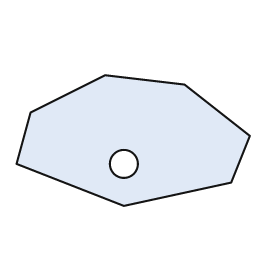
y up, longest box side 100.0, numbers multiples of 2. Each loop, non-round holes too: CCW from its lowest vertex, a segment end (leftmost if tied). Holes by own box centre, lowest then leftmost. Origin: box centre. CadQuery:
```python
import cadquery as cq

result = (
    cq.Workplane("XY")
    .moveTo(-4.0, -28.0)
    .lineTo(42.0, -18.0)
    .lineTo(50.0, 2.0)
    .lineTo(22.0, 24.0)
    .lineTo(-12.0, 28.0)
    .lineTo(-44.0, 12.0)
    .lineTo(-50.0, -10.0)
    .close()
    .moveTo(-4.0, -10.0)
    .circle(6.0)
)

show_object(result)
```